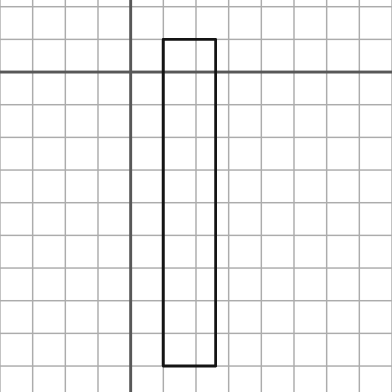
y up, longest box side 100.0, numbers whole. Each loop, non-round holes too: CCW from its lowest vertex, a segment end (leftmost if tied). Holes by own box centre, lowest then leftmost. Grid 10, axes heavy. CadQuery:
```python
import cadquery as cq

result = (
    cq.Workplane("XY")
    .moveTo(10.0, -90.0)
    .lineTo(26.0, -90.0)
    .lineTo(26.0, 10.0)
    .lineTo(10.0, 10.0)
    .close()
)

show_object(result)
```